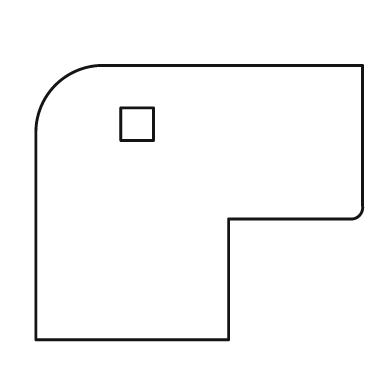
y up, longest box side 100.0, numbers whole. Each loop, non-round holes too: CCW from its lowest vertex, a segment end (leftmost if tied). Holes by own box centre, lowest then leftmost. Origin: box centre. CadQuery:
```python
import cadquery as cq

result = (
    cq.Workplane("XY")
    .moveTo(-50.0, -42.0)
    .lineTo(9.0, -42.0)
    .lineTo(9.0, -5.0)
    .lineTo(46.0, -5.0)
    .threePointArc((49.0, -4.0), (50.0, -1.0))
    .lineTo(50.0, 42.0)
    .lineTo(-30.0, 42.0)
    .threePointArc((-44.0, 36.0), (-50.0, 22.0))
    .close()
    .moveTo(-24.0, 19.0)
    .lineTo(-14.0, 19.0)
    .lineTo(-14.0, 29.0)
    .lineTo(-24.0, 29.0)
    .close()
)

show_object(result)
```